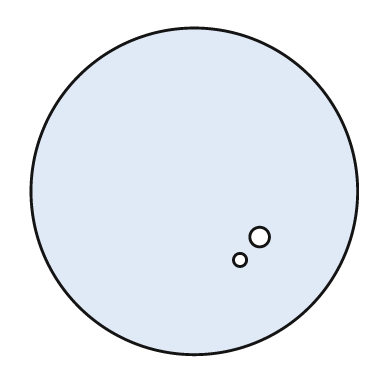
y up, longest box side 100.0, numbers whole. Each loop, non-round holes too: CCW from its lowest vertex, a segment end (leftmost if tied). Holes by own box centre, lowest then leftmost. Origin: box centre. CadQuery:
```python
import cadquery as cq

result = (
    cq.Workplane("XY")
    .moveTo(0.0, 0.0)
    .circle(50.0)
    .moveTo(14.0, -21.0)
    .circle(2.0)
    .moveTo(20.0, -14.0)
    .circle(3.0)
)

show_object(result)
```